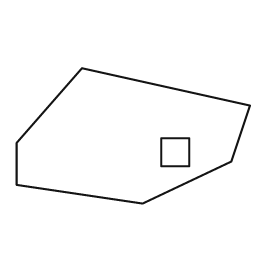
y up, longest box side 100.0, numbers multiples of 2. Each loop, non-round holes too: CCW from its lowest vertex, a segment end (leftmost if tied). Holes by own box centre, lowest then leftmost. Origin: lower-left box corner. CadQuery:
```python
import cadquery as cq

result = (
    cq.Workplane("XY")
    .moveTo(54.0, 0.0)
    .lineTo(92.0, 18.0)
    .lineTo(100.0, 42.0)
    .lineTo(28.0, 58.0)
    .lineTo(0.0, 26.0)
    .lineTo(0.0, 8.0)
    .close()
    .moveTo(62.0, 16.0)
    .lineTo(74.0, 16.0)
    .lineTo(74.0, 28.0)
    .lineTo(62.0, 28.0)
    .close()
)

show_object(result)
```